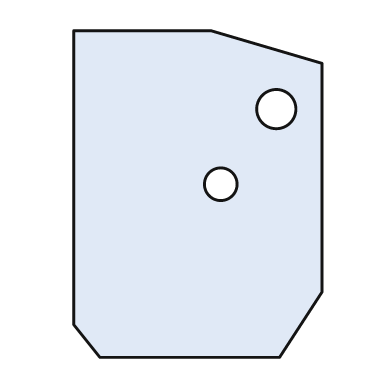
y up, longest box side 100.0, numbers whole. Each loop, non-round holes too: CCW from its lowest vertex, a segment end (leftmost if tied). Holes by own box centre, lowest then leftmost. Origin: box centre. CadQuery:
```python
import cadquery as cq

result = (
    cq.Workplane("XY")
    .moveTo(-30.0, -50.0)
    .lineTo(25.0, -50.0)
    .lineTo(38.0, -30.0)
    .lineTo(38.0, 40.0)
    .lineTo(4.0, 50.0)
    .lineTo(-38.0, 50.0)
    .lineTo(-38.0, -40.0)
    .close()
    .moveTo(7.0, 3.0)
    .circle(5.0)
    .moveTo(24.0, 26.0)
    .circle(6.0)
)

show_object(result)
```